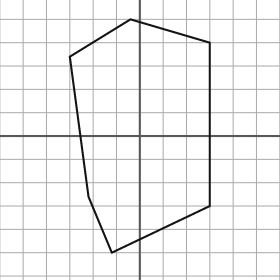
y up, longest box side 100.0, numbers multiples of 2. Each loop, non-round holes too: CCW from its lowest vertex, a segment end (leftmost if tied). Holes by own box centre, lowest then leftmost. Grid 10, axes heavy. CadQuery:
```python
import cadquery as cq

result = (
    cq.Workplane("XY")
    .moveTo(-12.0, -50.0)
    .lineTo(30.0, -30.0)
    .lineTo(30.0, 40.0)
    .lineTo(-4.0, 50.0)
    .lineTo(-30.0, 34.0)
    .lineTo(-22.0, -26.0)
    .close()
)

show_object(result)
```